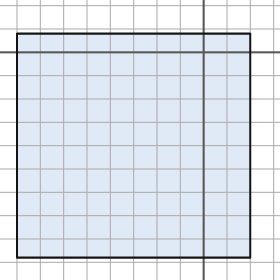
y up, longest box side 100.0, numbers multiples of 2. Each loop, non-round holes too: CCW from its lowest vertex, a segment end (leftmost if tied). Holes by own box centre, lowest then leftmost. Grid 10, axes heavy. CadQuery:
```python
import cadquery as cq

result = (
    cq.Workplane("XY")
    .moveTo(-80.0, -88.0)
    .lineTo(20.0, -88.0)
    .lineTo(20.0, 8.0)
    .lineTo(-80.0, 8.0)
    .close()
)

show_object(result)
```